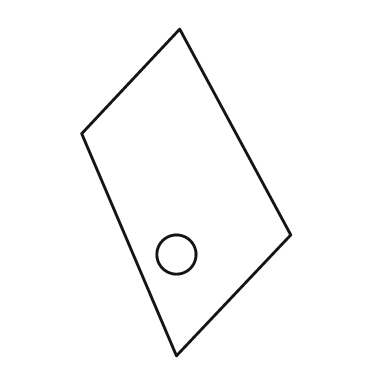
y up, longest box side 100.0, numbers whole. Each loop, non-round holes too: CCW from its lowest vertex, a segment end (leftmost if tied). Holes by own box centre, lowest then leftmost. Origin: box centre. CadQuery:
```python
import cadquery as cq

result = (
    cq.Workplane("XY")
    .moveTo(-3.0, -50.0)
    .lineTo(32.0, -13.0)
    .lineTo(-2.0, 50.0)
    .lineTo(-32.0, 18.0)
    .close()
    .moveTo(-3.0, -19.0)
    .circle(6.0)
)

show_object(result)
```